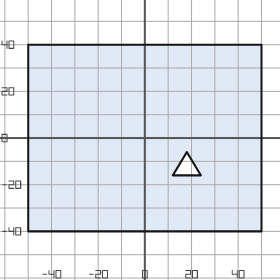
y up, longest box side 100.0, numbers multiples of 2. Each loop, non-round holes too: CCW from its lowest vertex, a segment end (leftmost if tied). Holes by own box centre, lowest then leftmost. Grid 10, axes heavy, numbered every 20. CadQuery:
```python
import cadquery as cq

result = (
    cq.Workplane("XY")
    .moveTo(-50.0, -40.0)
    .lineTo(50.0, -40.0)
    .lineTo(50.0, 40.0)
    .lineTo(-50.0, 40.0)
    .close()
    .moveTo(12.0, -16.0)
    .lineTo(24.0, -16.0)
    .lineTo(18.0, -6.0)
    .close()
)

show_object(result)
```